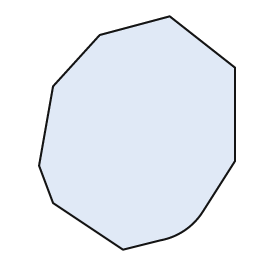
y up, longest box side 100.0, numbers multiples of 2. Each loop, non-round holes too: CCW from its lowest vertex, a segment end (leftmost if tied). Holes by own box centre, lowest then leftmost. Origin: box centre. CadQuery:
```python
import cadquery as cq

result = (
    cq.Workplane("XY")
    .moveTo(-6.0, -50.0)
    .lineTo(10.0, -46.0)
    .threePointArc((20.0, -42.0), (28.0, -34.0))
    .lineTo(42.0, -12.0)
    .lineTo(42.0, 28.0)
    .lineTo(14.0, 50.0)
    .lineTo(-16.0, 42.0)
    .lineTo(-36.0, 20.0)
    .lineTo(-42.0, -14.0)
    .lineTo(-36.0, -30.0)
    .close()
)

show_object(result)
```